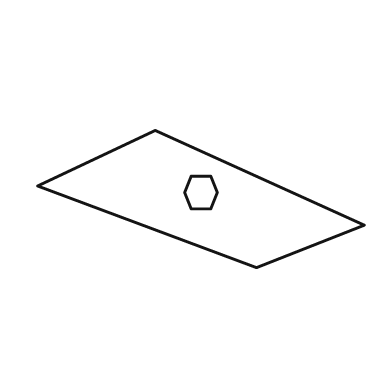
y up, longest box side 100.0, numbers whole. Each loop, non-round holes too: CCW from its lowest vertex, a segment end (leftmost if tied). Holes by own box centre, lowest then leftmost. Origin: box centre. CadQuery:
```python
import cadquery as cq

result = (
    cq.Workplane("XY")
    .moveTo(17.0, -21.0)
    .lineTo(50.0, -8.0)
    .lineTo(-14.0, 21.0)
    .lineTo(-50.0, 4.0)
    .close()
    .moveTo(-3.0, -3.0)
    .lineTo(3.0, -3.0)
    .lineTo(5.0, 2.0)
    .lineTo(3.0, 7.0)
    .lineTo(-3.0, 7.0)
    .lineTo(-5.0, 2.0)
    .close()
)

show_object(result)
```